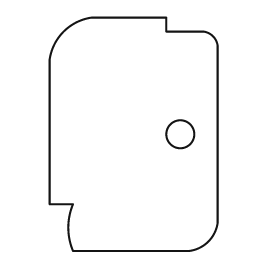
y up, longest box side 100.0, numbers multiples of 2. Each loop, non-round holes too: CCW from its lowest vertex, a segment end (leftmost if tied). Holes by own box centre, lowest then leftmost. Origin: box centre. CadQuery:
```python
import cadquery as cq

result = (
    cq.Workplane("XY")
    .moveTo(-26.0, -50.0)
    .lineTo(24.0, -50.0)
    .threePointArc((32.0, -46.0), (36.0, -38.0))
    .lineTo(36.0, 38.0)
    .threePointArc((34.0, 42.0), (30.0, 44.0))
    .lineTo(14.0, 44.0)
    .lineTo(14.0, 50.0)
    .lineTo(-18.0, 50.0)
    .threePointArc((-30.0, 44.0), (-36.0, 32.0))
    .lineTo(-36.0, -30.0)
    .lineTo(-26.0, -30.0)
    .threePointArc((-28.0, -40.0), (-26.0, -50.0))
    .close()
    .moveTo(20.0, 0.0)
    .circle(6.0)
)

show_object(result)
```